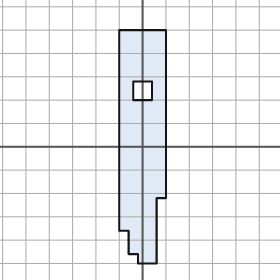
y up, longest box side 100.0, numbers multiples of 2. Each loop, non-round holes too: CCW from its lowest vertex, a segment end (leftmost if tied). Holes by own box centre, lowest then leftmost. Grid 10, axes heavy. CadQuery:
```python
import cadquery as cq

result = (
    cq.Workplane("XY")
    .moveTo(-2.0, -50.0)
    .lineTo(6.0, -50.0)
    .lineTo(6.0, -22.0)
    .lineTo(10.0, -22.0)
    .lineTo(10.0, 50.0)
    .lineTo(-10.0, 50.0)
    .lineTo(-10.0, -36.0)
    .lineTo(-6.0, -36.0)
    .lineTo(-6.0, -46.0)
    .lineTo(-2.0, -46.0)
    .close()
    .moveTo(-4.0, 20.0)
    .lineTo(4.0, 20.0)
    .lineTo(4.0, 28.0)
    .lineTo(-4.0, 28.0)
    .close()
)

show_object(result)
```